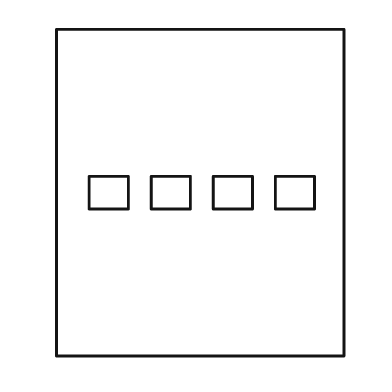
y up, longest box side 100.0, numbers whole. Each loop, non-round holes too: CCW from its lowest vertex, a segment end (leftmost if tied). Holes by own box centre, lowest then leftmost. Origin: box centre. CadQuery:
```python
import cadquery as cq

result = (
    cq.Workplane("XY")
    .moveTo(-44.0, -50.0)
    .lineTo(44.0, -50.0)
    .lineTo(44.0, 50.0)
    .lineTo(-44.0, 50.0)
    .close()
    .moveTo(-34.0, -5.0)
    .lineTo(-22.0, -5.0)
    .lineTo(-22.0, 5.0)
    .lineTo(-34.0, 5.0)
    .close()
    .moveTo(-15.0, -5.0)
    .lineTo(-3.0, -5.0)
    .lineTo(-3.0, 5.0)
    .lineTo(-15.0, 5.0)
    .close()
    .moveTo(4.0, -5.0)
    .lineTo(16.0, -5.0)
    .lineTo(16.0, 5.0)
    .lineTo(4.0, 5.0)
    .close()
    .moveTo(23.0, -5.0)
    .lineTo(35.0, -5.0)
    .lineTo(35.0, 5.0)
    .lineTo(23.0, 5.0)
    .close()
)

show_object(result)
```